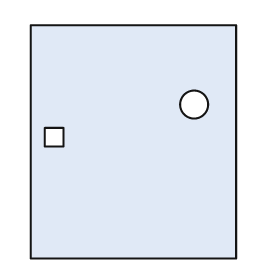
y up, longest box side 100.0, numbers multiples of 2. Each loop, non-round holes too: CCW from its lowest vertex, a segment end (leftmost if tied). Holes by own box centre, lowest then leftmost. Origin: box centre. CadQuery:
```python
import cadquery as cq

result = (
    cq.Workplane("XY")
    .moveTo(-44.0, -50.0)
    .lineTo(44.0, -50.0)
    .lineTo(44.0, 50.0)
    .lineTo(-44.0, 50.0)
    .close()
    .moveTo(-38.0, -2.0)
    .lineTo(-30.0, -2.0)
    .lineTo(-30.0, 6.0)
    .lineTo(-38.0, 6.0)
    .close()
    .moveTo(26.0, 16.0)
    .circle(6.0)
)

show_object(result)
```